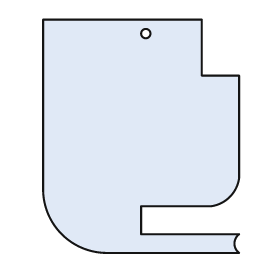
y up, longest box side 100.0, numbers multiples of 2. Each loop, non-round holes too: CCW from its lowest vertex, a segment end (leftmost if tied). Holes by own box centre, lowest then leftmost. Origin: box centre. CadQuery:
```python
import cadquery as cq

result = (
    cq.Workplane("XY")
    .moveTo(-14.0, -50.0)
    .lineTo(42.0, -50.0)
    .threePointArc((40.0, -46.0), (42.0, -42.0))
    .lineTo(0.0, -42.0)
    .lineTo(0.0, -30.0)
    .lineTo(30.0, -30.0)
    .threePointArc((38.0, -26.0), (42.0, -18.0))
    .lineTo(42.0, 26.0)
    .lineTo(26.0, 26.0)
    .lineTo(26.0, 50.0)
    .lineTo(-42.0, 50.0)
    .lineTo(-42.0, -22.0)
    .threePointArc((-34.0, -42.0), (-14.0, -50.0))
    .close()
    .moveTo(2.0, 44.0)
    .circle(2.0)
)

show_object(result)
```